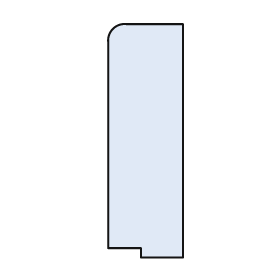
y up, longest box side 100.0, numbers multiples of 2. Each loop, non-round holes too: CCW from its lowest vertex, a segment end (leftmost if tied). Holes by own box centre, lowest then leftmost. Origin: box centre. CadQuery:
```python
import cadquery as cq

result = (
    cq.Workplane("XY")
    .moveTo(-2.0, -50.0)
    .lineTo(16.0, -50.0)
    .lineTo(16.0, 50.0)
    .lineTo(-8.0, 50.0)
    .threePointArc((-14.0, 48.0), (-16.0, 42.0))
    .lineTo(-16.0, -46.0)
    .lineTo(-2.0, -46.0)
    .close()
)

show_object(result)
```